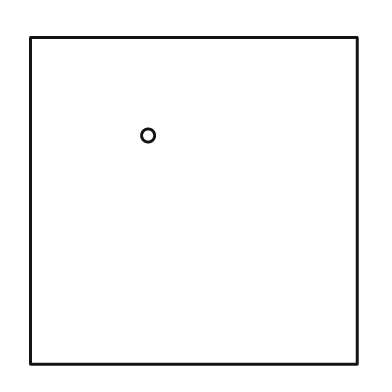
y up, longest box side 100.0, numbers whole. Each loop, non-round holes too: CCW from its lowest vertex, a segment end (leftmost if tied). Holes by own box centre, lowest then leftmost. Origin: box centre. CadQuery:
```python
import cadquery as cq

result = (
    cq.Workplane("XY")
    .moveTo(-50.0, -50.0)
    .lineTo(50.0, -50.0)
    .lineTo(50.0, 50.0)
    .lineTo(-50.0, 50.0)
    .close()
    .moveTo(-14.0, 20.0)
    .circle(2.0)
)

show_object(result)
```